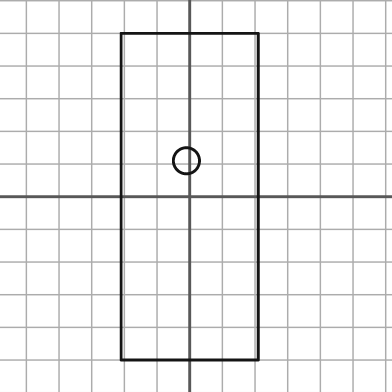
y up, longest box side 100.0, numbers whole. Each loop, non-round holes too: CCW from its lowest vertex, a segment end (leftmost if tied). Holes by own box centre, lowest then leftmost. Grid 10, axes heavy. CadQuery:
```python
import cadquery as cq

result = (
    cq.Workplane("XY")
    .moveTo(-21.0, -50.0)
    .lineTo(21.0, -50.0)
    .lineTo(21.0, 50.0)
    .lineTo(-21.0, 50.0)
    .close()
    .moveTo(-1.0, 11.0)
    .circle(4.0)
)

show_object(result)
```